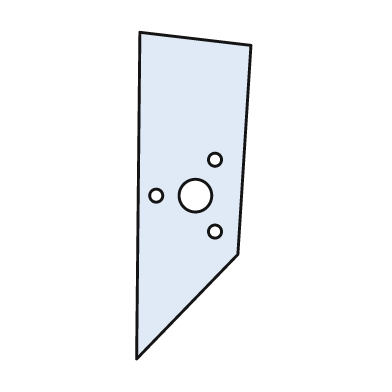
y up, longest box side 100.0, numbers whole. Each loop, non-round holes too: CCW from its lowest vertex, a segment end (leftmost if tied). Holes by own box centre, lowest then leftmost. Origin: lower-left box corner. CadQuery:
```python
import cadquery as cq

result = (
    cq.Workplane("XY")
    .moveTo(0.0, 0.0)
    .lineTo(31.0, 32.0)
    .lineTo(35.0, 96.0)
    .lineTo(1.0, 100.0)
    .close()
    .moveTo(24.0, 39.0)
    .circle(2.0)
    .moveTo(6.0, 50.0)
    .circle(2.0)
    .moveTo(18.0, 50.0)
    .circle(5.0)
    .moveTo(24.0, 61.0)
    .circle(2.0)
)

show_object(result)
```